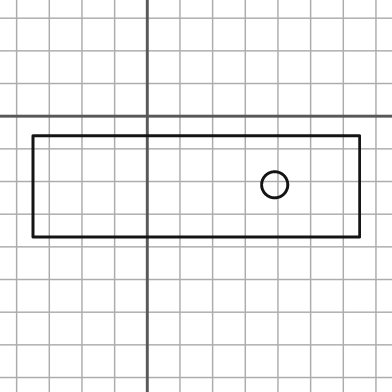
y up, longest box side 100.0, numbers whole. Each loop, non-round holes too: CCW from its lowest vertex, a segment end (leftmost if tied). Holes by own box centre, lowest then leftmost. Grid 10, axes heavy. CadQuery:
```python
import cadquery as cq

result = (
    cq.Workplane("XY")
    .moveTo(-35.0, -37.0)
    .lineTo(65.0, -37.0)
    .lineTo(65.0, -6.0)
    .lineTo(-35.0, -6.0)
    .close()
    .moveTo(39.0, -21.0)
    .circle(4.0)
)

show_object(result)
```